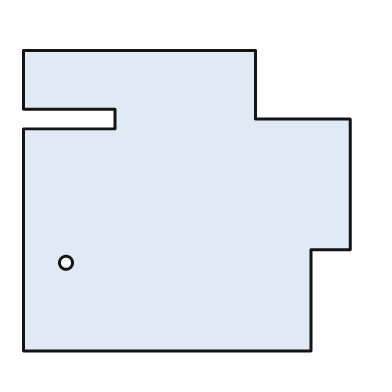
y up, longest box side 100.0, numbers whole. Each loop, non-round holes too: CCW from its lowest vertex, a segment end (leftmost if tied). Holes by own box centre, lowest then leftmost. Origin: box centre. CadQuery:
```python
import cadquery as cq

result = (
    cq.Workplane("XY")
    .moveTo(-50.0, -46.0)
    .lineTo(38.0, -46.0)
    .lineTo(38.0, -15.0)
    .lineTo(50.0, -15.0)
    .lineTo(50.0, 25.0)
    .lineTo(21.0, 25.0)
    .lineTo(21.0, 46.0)
    .lineTo(-50.0, 46.0)
    .lineTo(-50.0, 28.0)
    .lineTo(-22.0, 28.0)
    .lineTo(-22.0, 22.0)
    .lineTo(-50.0, 22.0)
    .close()
    .moveTo(-37.0, -19.0)
    .circle(2.0)
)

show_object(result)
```